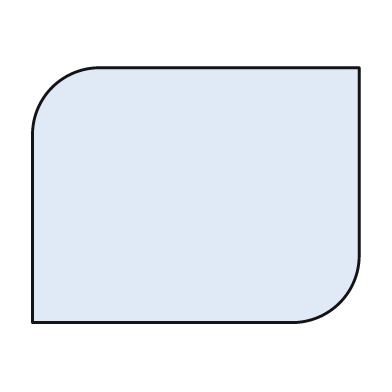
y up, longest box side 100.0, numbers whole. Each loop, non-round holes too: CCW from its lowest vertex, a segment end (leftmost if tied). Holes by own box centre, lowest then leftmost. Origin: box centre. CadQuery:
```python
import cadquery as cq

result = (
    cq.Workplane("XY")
    .moveTo(-50.0, -39.0)
    .lineTo(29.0, -39.0)
    .threePointArc((44.0, -33.0), (50.0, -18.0))
    .lineTo(50.0, 39.0)
    .lineTo(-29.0, 39.0)
    .threePointArc((-44.0, 33.0), (-50.0, 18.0))
    .close()
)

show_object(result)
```